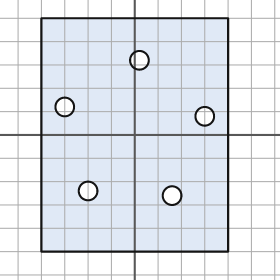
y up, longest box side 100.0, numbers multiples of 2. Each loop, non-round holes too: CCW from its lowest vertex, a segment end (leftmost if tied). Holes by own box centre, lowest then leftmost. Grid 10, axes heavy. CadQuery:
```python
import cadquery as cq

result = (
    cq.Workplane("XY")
    .moveTo(-40.0, -50.0)
    .lineTo(40.0, -50.0)
    .lineTo(40.0, 50.0)
    .lineTo(-40.0, 50.0)
    .close()
    .moveTo(16.0, -26.0)
    .circle(4.0)
    .moveTo(-20.0, -24.0)
    .circle(4.0)
    .moveTo(30.0, 8.0)
    .circle(4.0)
    .moveTo(-30.0, 12.0)
    .circle(4.0)
    .moveTo(2.0, 32.0)
    .circle(4.0)
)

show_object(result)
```